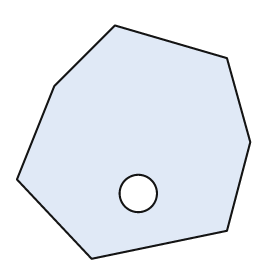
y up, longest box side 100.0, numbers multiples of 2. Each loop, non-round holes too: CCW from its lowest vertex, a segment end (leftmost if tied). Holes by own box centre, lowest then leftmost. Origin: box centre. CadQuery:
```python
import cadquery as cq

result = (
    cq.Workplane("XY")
    .moveTo(-18.0, -50.0)
    .lineTo(40.0, -38.0)
    .lineTo(50.0, 0.0)
    .lineTo(40.0, 36.0)
    .lineTo(-8.0, 50.0)
    .lineTo(-34.0, 24.0)
    .lineTo(-50.0, -16.0)
    .close()
    .moveTo(2.0, -22.0)
    .circle(8.0)
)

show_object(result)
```